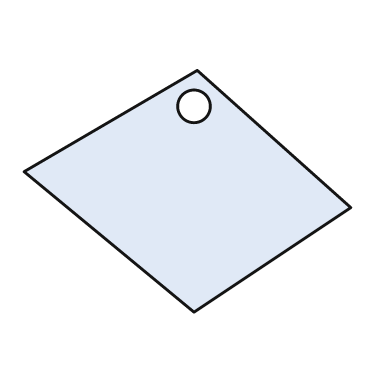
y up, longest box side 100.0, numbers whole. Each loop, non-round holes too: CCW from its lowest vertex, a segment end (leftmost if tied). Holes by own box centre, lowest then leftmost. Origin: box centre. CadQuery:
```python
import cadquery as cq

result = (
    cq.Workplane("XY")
    .moveTo(2.0, -37.0)
    .lineTo(50.0, -5.0)
    .lineTo(3.0, 37.0)
    .lineTo(-50.0, 6.0)
    .close()
    .moveTo(2.0, 26.0)
    .circle(5.0)
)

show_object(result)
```